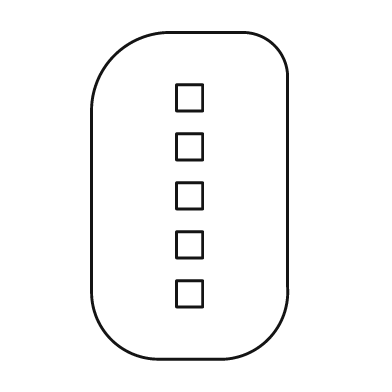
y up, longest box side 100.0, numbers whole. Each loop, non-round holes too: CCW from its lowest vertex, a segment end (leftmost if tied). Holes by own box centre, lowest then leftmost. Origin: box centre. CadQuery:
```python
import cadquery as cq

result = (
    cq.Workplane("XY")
    .moveTo(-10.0, -50.0)
    .lineTo(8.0, -50.0)
    .threePointArc((24.0, -44.0), (30.0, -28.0))
    .lineTo(30.0, 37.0)
    .threePointArc((26.0, 46.0), (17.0, 50.0))
    .lineTo(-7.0, 50.0)
    .threePointArc((-23.0, 43.0), (-30.0, 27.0))
    .lineTo(-30.0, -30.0)
    .threePointArc((-24.0, -44.0), (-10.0, -50.0))
    .close()
    .moveTo(-4.0, -34.0)
    .lineTo(4.0, -34.0)
    .lineTo(4.0, -26.0)
    .lineTo(-4.0, -26.0)
    .close()
    .moveTo(-4.0, -19.0)
    .lineTo(4.0, -19.0)
    .lineTo(4.0, -11.0)
    .lineTo(-4.0, -11.0)
    .close()
    .moveTo(-4.0, -4.0)
    .lineTo(4.0, -4.0)
    .lineTo(4.0, 4.0)
    .lineTo(-4.0, 4.0)
    .close()
    .moveTo(-4.0, 11.0)
    .lineTo(4.0, 11.0)
    .lineTo(4.0, 19.0)
    .lineTo(-4.0, 19.0)
    .close()
    .moveTo(-4.0, 26.0)
    .lineTo(4.0, 26.0)
    .lineTo(4.0, 34.0)
    .lineTo(-4.0, 34.0)
    .close()
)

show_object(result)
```